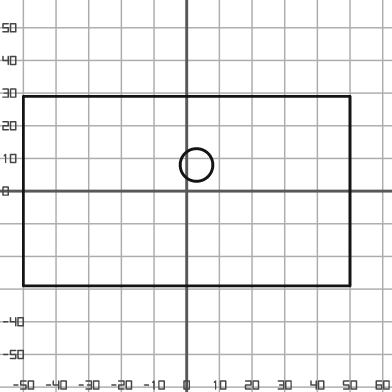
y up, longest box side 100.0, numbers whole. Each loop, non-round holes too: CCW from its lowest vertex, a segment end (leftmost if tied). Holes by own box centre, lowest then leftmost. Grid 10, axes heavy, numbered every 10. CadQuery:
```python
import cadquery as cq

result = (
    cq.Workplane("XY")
    .moveTo(-50.0, -29.0)
    .lineTo(50.0, -29.0)
    .lineTo(50.0, 29.0)
    .lineTo(-50.0, 29.0)
    .close()
    .moveTo(3.0, 8.0)
    .circle(5.0)
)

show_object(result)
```